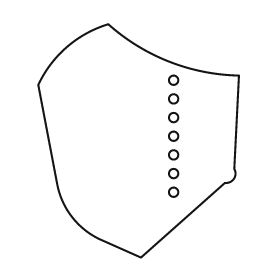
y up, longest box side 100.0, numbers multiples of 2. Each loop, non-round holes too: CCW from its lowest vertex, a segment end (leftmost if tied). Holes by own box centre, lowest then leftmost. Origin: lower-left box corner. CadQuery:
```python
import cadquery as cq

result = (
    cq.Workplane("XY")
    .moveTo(44.0, 0.0)
    .lineTo(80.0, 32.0)
    .threePointArc((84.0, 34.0), (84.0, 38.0))
    .lineTo(86.0, 78.0)
    .threePointArc((56.0, 84.0), (30.0, 100.0))
    .threePointArc((12.0, 90.0), (0.0, 74.0))
    .lineTo(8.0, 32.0)
    .threePointArc((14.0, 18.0), (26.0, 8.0))
    .close()
    .moveTo(58.0, 28.0)
    .circle(2.0)
    .moveTo(58.0, 36.0)
    .circle(2.0)
    .moveTo(58.0, 44.0)
    .circle(2.0)
    .moveTo(58.0, 52.0)
    .circle(2.0)
    .moveTo(58.0, 60.0)
    .circle(2.0)
    .moveTo(58.0, 68.0)
    .circle(2.0)
    .moveTo(58.0, 76.0)
    .circle(2.0)
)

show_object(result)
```